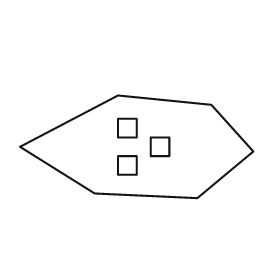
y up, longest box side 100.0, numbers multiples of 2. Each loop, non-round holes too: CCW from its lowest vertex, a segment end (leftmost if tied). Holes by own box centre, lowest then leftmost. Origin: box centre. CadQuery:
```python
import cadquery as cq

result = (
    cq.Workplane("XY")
    .moveTo(26.0, -22.0)
    .lineTo(50.0, -2.0)
    .lineTo(32.0, 18.0)
    .lineTo(-8.0, 22.0)
    .lineTo(-50.0, 0.0)
    .lineTo(-18.0, -20.0)
    .close()
    .moveTo(-8.0, -12.0)
    .lineTo(0.0, -12.0)
    .lineTo(0.0, -4.0)
    .lineTo(-8.0, -4.0)
    .close()
    .moveTo(6.0, -4.0)
    .lineTo(14.0, -4.0)
    .lineTo(14.0, 4.0)
    .lineTo(6.0, 4.0)
    .close()
    .moveTo(-8.0, 4.0)
    .lineTo(0.0, 4.0)
    .lineTo(0.0, 12.0)
    .lineTo(-8.0, 12.0)
    .close()
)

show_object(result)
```